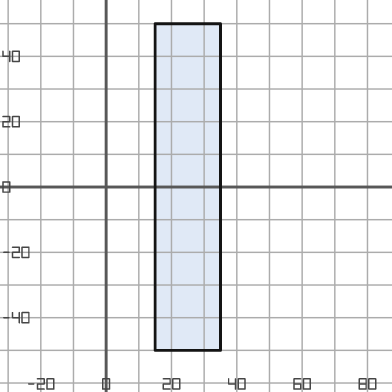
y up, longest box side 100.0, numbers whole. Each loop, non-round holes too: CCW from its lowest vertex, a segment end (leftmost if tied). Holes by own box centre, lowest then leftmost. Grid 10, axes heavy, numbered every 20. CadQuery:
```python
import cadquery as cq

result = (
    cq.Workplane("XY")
    .moveTo(15.0, -50.0)
    .lineTo(35.0, -50.0)
    .lineTo(35.0, 50.0)
    .lineTo(15.0, 50.0)
    .close()
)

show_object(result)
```